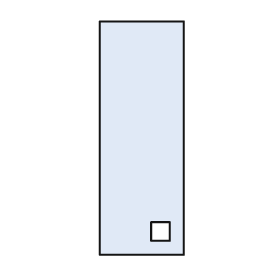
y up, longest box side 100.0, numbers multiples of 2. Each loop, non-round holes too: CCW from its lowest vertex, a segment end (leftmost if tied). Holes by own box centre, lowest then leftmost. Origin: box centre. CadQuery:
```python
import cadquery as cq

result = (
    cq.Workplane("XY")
    .moveTo(-18.0, -50.0)
    .lineTo(18.0, -50.0)
    .lineTo(18.0, 50.0)
    .lineTo(-18.0, 50.0)
    .close()
    .moveTo(4.0, -44.0)
    .lineTo(12.0, -44.0)
    .lineTo(12.0, -36.0)
    .lineTo(4.0, -36.0)
    .close()
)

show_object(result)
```